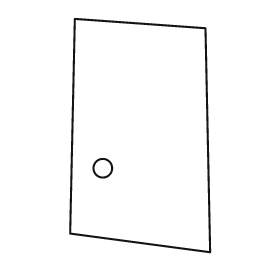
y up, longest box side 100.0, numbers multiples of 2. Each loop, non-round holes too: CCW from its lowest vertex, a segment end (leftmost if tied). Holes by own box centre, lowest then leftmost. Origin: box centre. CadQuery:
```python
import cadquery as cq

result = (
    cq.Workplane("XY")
    .moveTo(30.0, -50.0)
    .lineTo(28.0, 46.0)
    .lineTo(-28.0, 50.0)
    .lineTo(-30.0, -42.0)
    .close()
    .moveTo(-16.0, -14.0)
    .circle(4.0)
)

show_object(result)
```